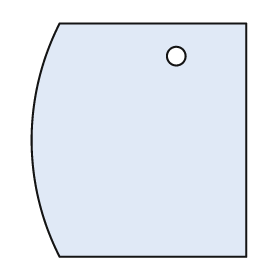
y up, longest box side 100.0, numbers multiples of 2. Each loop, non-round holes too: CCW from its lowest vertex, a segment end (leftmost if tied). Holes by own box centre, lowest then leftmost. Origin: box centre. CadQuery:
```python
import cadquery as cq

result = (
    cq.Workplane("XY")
    .moveTo(-34.0, -50.0)
    .lineTo(46.0, -50.0)
    .lineTo(46.0, 50.0)
    .lineTo(-34.0, 50.0)
    .threePointArc((-46.0, 0.0), (-34.0, -50.0))
    .close()
    .moveTo(16.0, 36.0)
    .circle(4.0)
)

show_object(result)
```